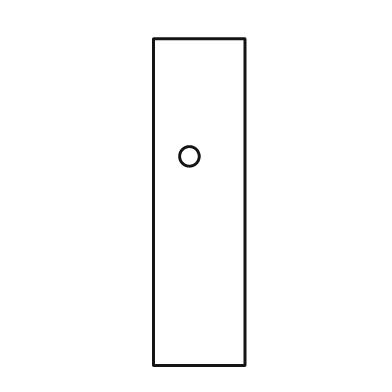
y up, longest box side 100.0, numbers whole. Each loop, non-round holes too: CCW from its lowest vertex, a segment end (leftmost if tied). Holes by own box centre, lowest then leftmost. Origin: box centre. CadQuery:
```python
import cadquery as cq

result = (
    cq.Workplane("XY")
    .moveTo(-14.0, -50.0)
    .lineTo(14.0, -50.0)
    .lineTo(14.0, 50.0)
    .lineTo(-14.0, 50.0)
    .close()
    .moveTo(-3.0, 14.0)
    .circle(3.0)
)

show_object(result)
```